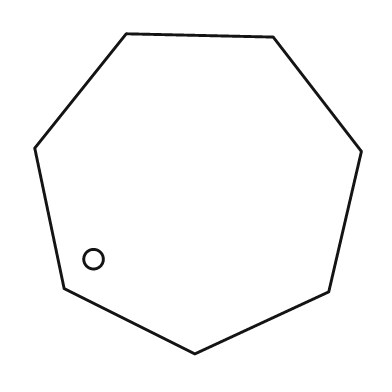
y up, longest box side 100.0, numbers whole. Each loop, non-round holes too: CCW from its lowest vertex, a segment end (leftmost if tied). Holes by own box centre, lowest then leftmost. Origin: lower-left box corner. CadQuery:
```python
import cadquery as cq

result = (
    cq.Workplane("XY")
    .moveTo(49.0, 0.0)
    .lineTo(90.0, 19.0)
    .lineTo(100.0, 62.0)
    .lineTo(73.0, 97.0)
    .lineTo(28.0, 98.0)
    .lineTo(0.0, 63.0)
    .lineTo(9.0, 20.0)
    .close()
    .moveTo(18.0, 29.0)
    .circle(3.0)
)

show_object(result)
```